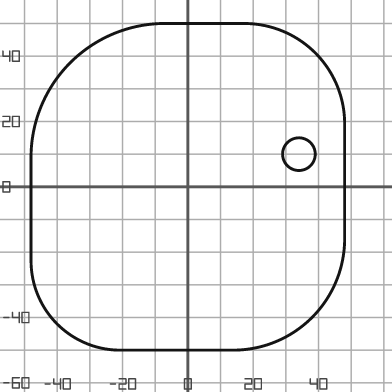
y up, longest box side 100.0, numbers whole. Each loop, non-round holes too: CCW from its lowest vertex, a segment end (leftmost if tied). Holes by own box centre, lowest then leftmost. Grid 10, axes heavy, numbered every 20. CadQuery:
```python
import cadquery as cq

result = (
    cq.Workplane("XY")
    .moveTo(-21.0, -50.0)
    .lineTo(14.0, -50.0)
    .threePointArc((38.0, -40.0), (48.0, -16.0))
    .lineTo(48.0, 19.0)
    .threePointArc((39.0, 41.0), (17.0, 50.0))
    .lineTo(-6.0, 50.0)
    .threePointArc((-36.0, 38.0), (-48.0, 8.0))
    .lineTo(-48.0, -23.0)
    .threePointArc((-40.0, -42.0), (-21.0, -50.0))
    .close()
    .moveTo(34.0, 10.0)
    .circle(5.0)
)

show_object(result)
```